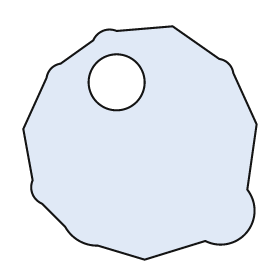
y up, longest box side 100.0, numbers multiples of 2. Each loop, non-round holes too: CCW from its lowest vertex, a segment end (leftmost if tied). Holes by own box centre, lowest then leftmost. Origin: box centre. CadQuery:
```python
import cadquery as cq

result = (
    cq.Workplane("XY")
    .moveTo(2.0, -50.0)
    .lineTo(28.0, -42.0)
    .threePointArc((46.0, -38.0), (46.0, -20.0))
    .lineTo(50.0, 8.0)
    .lineTo(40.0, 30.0)
    .threePointArc((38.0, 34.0), (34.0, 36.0))
    .lineTo(14.0, 50.0)
    .lineTo(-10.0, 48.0)
    .threePointArc((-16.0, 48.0), (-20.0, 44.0))
    .lineTo(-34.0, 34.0)
    .threePointArc((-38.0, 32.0), (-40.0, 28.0))
    .lineTo(-50.0, 6.0)
    .lineTo(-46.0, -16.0)
    .threePointArc((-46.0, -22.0), (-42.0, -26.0))
    .lineTo(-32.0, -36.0)
    .threePointArc((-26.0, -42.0), (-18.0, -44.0))
    .close()
    .moveTo(-10.0, 26.0)
    .circle(12.0)
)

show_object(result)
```